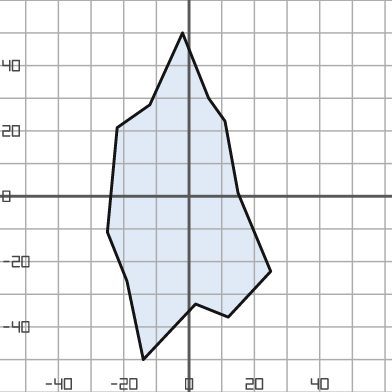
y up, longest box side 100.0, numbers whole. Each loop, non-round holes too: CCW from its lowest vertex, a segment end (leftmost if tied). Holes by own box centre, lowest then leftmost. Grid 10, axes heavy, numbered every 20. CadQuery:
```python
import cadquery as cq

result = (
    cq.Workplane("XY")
    .moveTo(-14.0, -50.0)
    .lineTo(2.0, -33.0)
    .lineTo(12.0, -37.0)
    .lineTo(25.0, -23.0)
    .lineTo(15.0, 1.0)
    .lineTo(11.0, 23.0)
    .lineTo(6.0, 30.0)
    .lineTo(-2.0, 50.0)
    .lineTo(-12.0, 28.0)
    .lineTo(-22.0, 21.0)
    .lineTo(-25.0, -11.0)
    .lineTo(-19.0, -26.0)
    .close()
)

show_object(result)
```